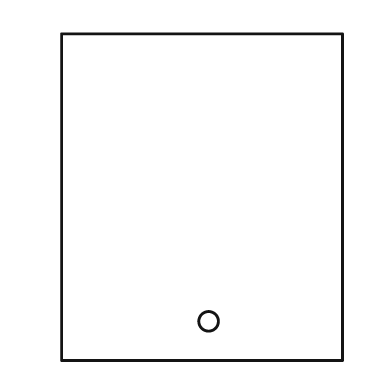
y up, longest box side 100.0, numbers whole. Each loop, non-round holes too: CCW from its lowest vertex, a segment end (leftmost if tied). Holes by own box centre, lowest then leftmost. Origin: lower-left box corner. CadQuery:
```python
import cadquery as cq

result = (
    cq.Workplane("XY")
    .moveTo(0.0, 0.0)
    .lineTo(86.0, 0.0)
    .lineTo(86.0, 100.0)
    .lineTo(0.0, 100.0)
    .close()
    .moveTo(45.0, 12.0)
    .circle(3.0)
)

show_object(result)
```